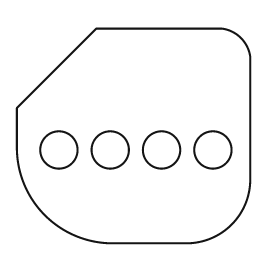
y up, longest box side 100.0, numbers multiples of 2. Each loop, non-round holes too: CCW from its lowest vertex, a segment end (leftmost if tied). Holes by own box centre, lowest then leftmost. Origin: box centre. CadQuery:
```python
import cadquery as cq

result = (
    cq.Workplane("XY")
    .moveTo(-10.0, -46.0)
    .lineTo(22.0, -46.0)
    .threePointArc((42.0, -38.0), (50.0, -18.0))
    .lineTo(50.0, 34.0)
    .threePointArc((46.0, 42.0), (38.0, 46.0))
    .lineTo(-16.0, 46.0)
    .lineTo(-50.0, 12.0)
    .lineTo(-50.0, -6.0)
    .threePointArc((-38.0, -34.0), (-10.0, -46.0))
    .close()
    .moveTo(-32.0, -6.0)
    .circle(8.0)
    .moveTo(-10.0, -6.0)
    .circle(8.0)
    .moveTo(12.0, -6.0)
    .circle(8.0)
    .moveTo(34.0, -6.0)
    .circle(8.0)
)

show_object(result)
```